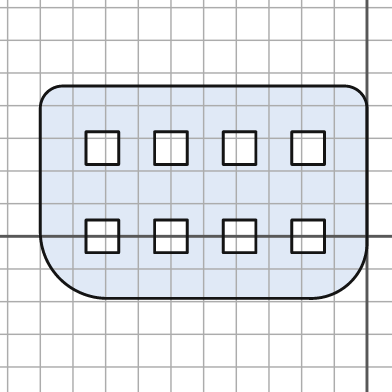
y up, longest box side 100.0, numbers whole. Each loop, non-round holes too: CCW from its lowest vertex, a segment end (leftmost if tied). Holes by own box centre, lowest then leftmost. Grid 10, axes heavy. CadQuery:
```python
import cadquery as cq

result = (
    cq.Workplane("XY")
    .moveTo(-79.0, -19.0)
    .lineTo(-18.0, -19.0)
    .threePointArc((-5.0, -14.0), (0.0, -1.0))
    .lineTo(0.0, 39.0)
    .threePointArc((-2.0, 44.0), (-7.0, 46.0))
    .lineTo(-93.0, 46.0)
    .threePointArc((-98.0, 44.0), (-100.0, 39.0))
    .lineTo(-100.0, 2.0)
    .threePointArc((-94.0, -13.0), (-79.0, -19.0))
    .close()
    .moveTo(-86.0, -5.0)
    .lineTo(-76.0, -5.0)
    .lineTo(-76.0, 5.0)
    .lineTo(-86.0, 5.0)
    .close()
    .moveTo(-65.0, -5.0)
    .lineTo(-55.0, -5.0)
    .lineTo(-55.0, 5.0)
    .lineTo(-65.0, 5.0)
    .close()
    .moveTo(-44.0, -5.0)
    .lineTo(-34.0, -5.0)
    .lineTo(-34.0, 5.0)
    .lineTo(-44.0, 5.0)
    .close()
    .moveTo(-23.0, -5.0)
    .lineTo(-13.0, -5.0)
    .lineTo(-13.0, 5.0)
    .lineTo(-23.0, 5.0)
    .close()
    .moveTo(-86.0, 22.0)
    .lineTo(-76.0, 22.0)
    .lineTo(-76.0, 32.0)
    .lineTo(-86.0, 32.0)
    .close()
    .moveTo(-65.0, 22.0)
    .lineTo(-55.0, 22.0)
    .lineTo(-55.0, 32.0)
    .lineTo(-65.0, 32.0)
    .close()
    .moveTo(-44.0, 22.0)
    .lineTo(-34.0, 22.0)
    .lineTo(-34.0, 32.0)
    .lineTo(-44.0, 32.0)
    .close()
    .moveTo(-23.0, 22.0)
    .lineTo(-13.0, 22.0)
    .lineTo(-13.0, 32.0)
    .lineTo(-23.0, 32.0)
    .close()
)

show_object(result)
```